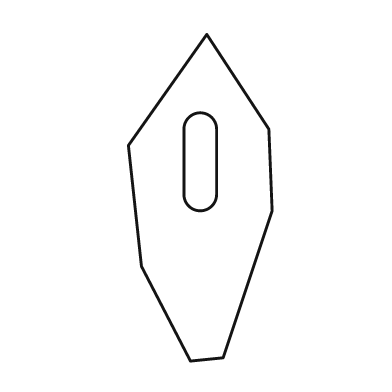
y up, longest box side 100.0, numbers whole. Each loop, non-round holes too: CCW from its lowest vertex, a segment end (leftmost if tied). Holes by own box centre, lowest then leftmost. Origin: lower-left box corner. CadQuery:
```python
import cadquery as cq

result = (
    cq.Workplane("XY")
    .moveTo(19.0, 0.0)
    .lineTo(29.0, 1.0)
    .lineTo(44.0, 46.0)
    .lineTo(43.0, 71.0)
    .lineTo(24.0, 100.0)
    .lineTo(0.0, 66.0)
    .lineTo(4.0, 29.0)
    .close()
    .moveTo(17.0, 51.0)
    .threePointArc((22.0, 46.0), (27.0, 51.0))
    .lineTo(27.0, 71.0)
    .threePointArc((22.0, 76.0), (17.0, 71.0))
    .close()
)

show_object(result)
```